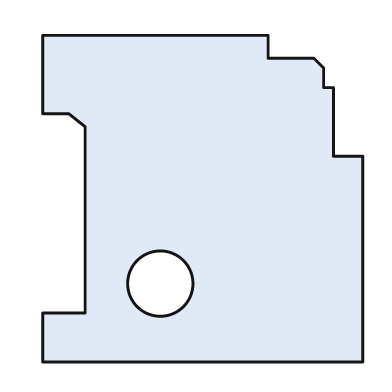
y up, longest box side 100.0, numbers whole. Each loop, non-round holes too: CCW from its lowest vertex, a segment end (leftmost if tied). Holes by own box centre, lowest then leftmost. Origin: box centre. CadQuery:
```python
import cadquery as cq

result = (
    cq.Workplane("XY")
    .moveTo(-49.0, -50.0)
    .lineTo(49.0, -50.0)
    .lineTo(49.0, 13.0)
    .lineTo(40.0, 13.0)
    .lineTo(40.0, 34.0)
    .lineTo(37.0, 34.0)
    .lineTo(37.0, 40.0)
    .lineTo(34.0, 43.0)
    .lineTo(20.0, 43.0)
    .lineTo(20.0, 50.0)
    .lineTo(-49.0, 50.0)
    .lineTo(-49.0, 26.0)
    .lineTo(-41.0, 26.0)
    .lineTo(-36.0, 22.0)
    .lineTo(-36.0, -35.0)
    .lineTo(-49.0, -35.0)
    .close()
    .moveTo(-13.0, -26.0)
    .circle(10.0)
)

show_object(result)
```